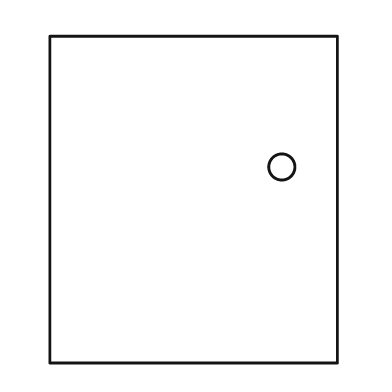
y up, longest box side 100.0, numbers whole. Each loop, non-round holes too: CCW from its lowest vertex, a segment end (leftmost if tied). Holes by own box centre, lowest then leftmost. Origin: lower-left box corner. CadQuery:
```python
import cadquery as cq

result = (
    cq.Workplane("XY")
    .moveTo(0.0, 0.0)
    .lineTo(88.0, 0.0)
    .lineTo(88.0, 100.0)
    .lineTo(0.0, 100.0)
    .close()
    .moveTo(71.0, 60.0)
    .circle(4.0)
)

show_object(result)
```